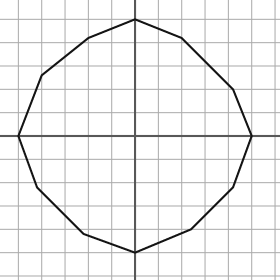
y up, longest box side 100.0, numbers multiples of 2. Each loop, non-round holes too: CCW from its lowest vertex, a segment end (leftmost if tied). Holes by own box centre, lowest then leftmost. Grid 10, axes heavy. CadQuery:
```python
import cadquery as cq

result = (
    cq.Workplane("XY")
    .moveTo(0.0, -50.0)
    .lineTo(24.0, -40.0)
    .lineTo(42.0, -22.0)
    .lineTo(50.0, 0.0)
    .lineTo(42.0, 20.0)
    .lineTo(20.0, 42.0)
    .lineTo(0.0, 50.0)
    .lineTo(-20.0, 42.0)
    .lineTo(-40.0, 26.0)
    .lineTo(-50.0, 0.0)
    .lineTo(-42.0, -22.0)
    .lineTo(-22.0, -42.0)
    .close()
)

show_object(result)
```